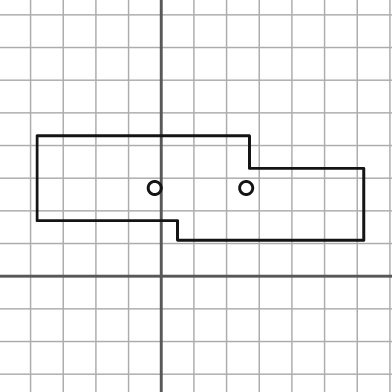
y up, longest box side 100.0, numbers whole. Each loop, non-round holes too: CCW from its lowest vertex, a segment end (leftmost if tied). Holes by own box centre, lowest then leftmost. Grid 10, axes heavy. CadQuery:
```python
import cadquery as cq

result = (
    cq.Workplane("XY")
    .moveTo(5.0, 11.0)
    .lineTo(62.0, 11.0)
    .lineTo(62.0, 33.0)
    .lineTo(27.0, 33.0)
    .lineTo(27.0, 43.0)
    .lineTo(-38.0, 43.0)
    .lineTo(-38.0, 17.0)
    .lineTo(5.0, 17.0)
    .close()
    .moveTo(-2.0, 27.0)
    .circle(2.0)
    .moveTo(26.0, 27.0)
    .circle(2.0)
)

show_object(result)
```